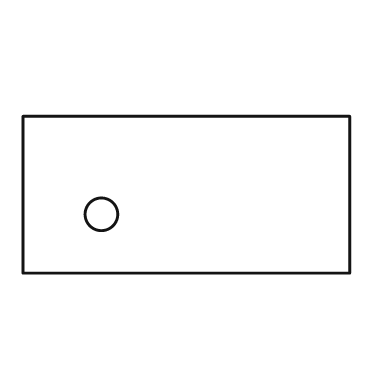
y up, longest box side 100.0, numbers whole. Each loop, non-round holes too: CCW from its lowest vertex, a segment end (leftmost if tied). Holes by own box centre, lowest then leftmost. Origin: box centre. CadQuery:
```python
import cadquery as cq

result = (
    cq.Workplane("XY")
    .moveTo(-50.0, -24.0)
    .lineTo(50.0, -24.0)
    .lineTo(50.0, 24.0)
    .lineTo(-50.0, 24.0)
    .close()
    .moveTo(-26.0, -6.0)
    .circle(5.0)
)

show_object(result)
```